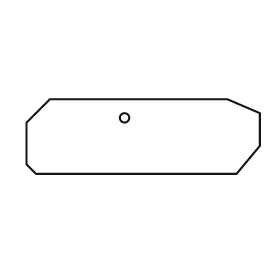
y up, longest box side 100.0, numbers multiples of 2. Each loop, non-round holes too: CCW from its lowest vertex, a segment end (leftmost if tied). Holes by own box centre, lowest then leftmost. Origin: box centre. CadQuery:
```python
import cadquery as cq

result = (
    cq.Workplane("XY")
    .moveTo(-46.0, -16.0)
    .lineTo(40.0, -16.0)
    .lineTo(50.0, -4.0)
    .lineTo(50.0, 10.0)
    .lineTo(36.0, 16.0)
    .lineTo(-40.0, 16.0)
    .lineTo(-50.0, 6.0)
    .lineTo(-50.0, -12.0)
    .close()
    .moveTo(-8.0, 8.0)
    .circle(2.0)
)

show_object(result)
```